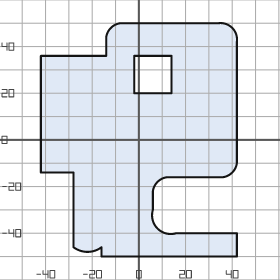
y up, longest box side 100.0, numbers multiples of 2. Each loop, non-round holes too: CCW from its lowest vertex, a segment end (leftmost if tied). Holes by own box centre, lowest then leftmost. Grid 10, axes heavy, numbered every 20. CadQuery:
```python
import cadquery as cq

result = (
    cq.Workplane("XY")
    .moveTo(-16.0, -50.0)
    .lineTo(42.0, -50.0)
    .lineTo(42.0, -40.0)
    .lineTo(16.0, -40.0)
    .threePointArc((8.0, -38.0), (6.0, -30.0))
    .lineTo(6.0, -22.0)
    .threePointArc((8.0, -18.0), (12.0, -16.0))
    .lineTo(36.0, -16.0)
    .threePointArc((40.0, -14.0), (42.0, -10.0))
    .lineTo(42.0, 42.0)
    .threePointArc((40.0, 48.0), (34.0, 50.0))
    .lineTo(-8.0, 50.0)
    .threePointArc((-12.0, 48.0), (-14.0, 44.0))
    .lineTo(-14.0, 36.0)
    .lineTo(-42.0, 36.0)
    .lineTo(-42.0, -14.0)
    .lineTo(-28.0, -14.0)
    .lineTo(-28.0, -46.0)
    .threePointArc((-22.0, -48.0), (-16.0, -46.0))
    .close()
    .moveTo(-2.0, 20.0)
    .lineTo(14.0, 20.0)
    .lineTo(14.0, 36.0)
    .lineTo(-2.0, 36.0)
    .close()
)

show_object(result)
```